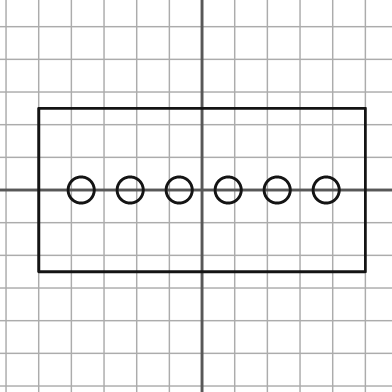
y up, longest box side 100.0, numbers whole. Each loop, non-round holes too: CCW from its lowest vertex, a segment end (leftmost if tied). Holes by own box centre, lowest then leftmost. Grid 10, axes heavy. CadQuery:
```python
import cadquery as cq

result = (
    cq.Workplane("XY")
    .moveTo(-50.0, -25.0)
    .lineTo(50.0, -25.0)
    .lineTo(50.0, 25.0)
    .lineTo(-50.0, 25.0)
    .close()
    .moveTo(-37.0, 0.0)
    .circle(4.0)
    .moveTo(-22.0, 0.0)
    .circle(4.0)
    .moveTo(-7.0, 0.0)
    .circle(4.0)
    .moveTo(8.0, 0.0)
    .circle(4.0)
    .moveTo(23.0, 0.0)
    .circle(4.0)
    .moveTo(38.0, 0.0)
    .circle(4.0)
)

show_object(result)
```